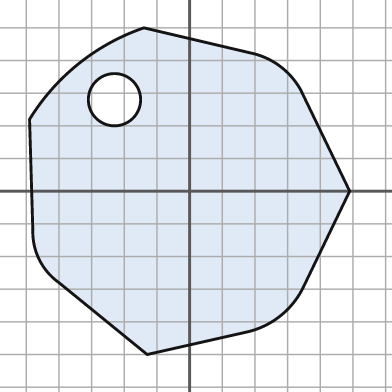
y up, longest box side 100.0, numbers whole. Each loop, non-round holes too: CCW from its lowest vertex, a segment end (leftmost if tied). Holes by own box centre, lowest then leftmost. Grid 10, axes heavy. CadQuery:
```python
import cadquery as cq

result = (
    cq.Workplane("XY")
    .moveTo(-13.0, -50.0)
    .lineTo(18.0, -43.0)
    .threePointArc((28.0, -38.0), (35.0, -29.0))
    .lineTo(49.0, 0.0)
    .lineTo(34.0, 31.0)
    .threePointArc((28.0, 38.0), (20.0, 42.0))
    .lineTo(-14.0, 50.0)
    .threePointArc((-34.0, 39.0), (-49.0, 22.0))
    .lineTo(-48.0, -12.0)
    .threePointArc((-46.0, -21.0), (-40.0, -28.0))
    .close()
    .moveTo(-23.0, 28.0)
    .circle(8.0)
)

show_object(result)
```